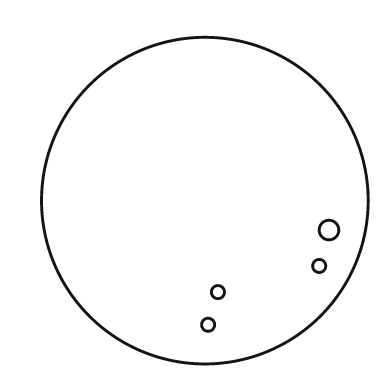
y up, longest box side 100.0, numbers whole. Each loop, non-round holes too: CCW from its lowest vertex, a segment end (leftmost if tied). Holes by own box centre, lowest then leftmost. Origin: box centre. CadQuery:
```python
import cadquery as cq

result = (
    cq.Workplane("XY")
    .moveTo(0.0, 0.0)
    .circle(50.0)
    .moveTo(1.0, -38.0)
    .circle(2.0)
    .moveTo(4.0, -28.0)
    .circle(2.0)
    .moveTo(35.0, -20.0)
    .circle(2.0)
    .moveTo(38.0, -9.0)
    .circle(3.0)
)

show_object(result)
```